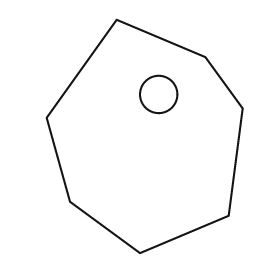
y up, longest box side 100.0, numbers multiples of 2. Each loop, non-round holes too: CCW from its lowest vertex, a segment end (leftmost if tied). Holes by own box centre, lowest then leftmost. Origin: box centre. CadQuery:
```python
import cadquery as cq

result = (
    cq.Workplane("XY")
    .moveTo(-2.0, -50.0)
    .lineTo(36.0, -34.0)
    .lineTo(42.0, 12.0)
    .lineTo(26.0, 34.0)
    .lineTo(-12.0, 50.0)
    .lineTo(-42.0, 8.0)
    .lineTo(-32.0, -28.0)
    .close()
    .moveTo(6.0, 18.0)
    .circle(8.0)
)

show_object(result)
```